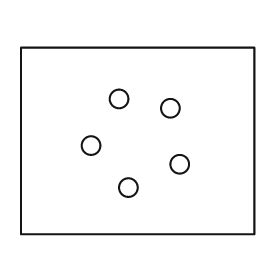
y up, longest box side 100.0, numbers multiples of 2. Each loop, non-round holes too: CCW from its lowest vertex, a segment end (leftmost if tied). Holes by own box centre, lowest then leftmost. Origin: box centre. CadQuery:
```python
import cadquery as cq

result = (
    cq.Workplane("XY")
    .moveTo(-50.0, -40.0)
    .lineTo(50.0, -40.0)
    .lineTo(50.0, 40.0)
    .lineTo(-50.0, 40.0)
    .close()
    .moveTo(-4.0, -20.0)
    .circle(4.0)
    .moveTo(18.0, -10.0)
    .circle(4.0)
    .moveTo(-20.0, -2.0)
    .circle(4.0)
    .moveTo(14.0, 14.0)
    .circle(4.0)
    .moveTo(-8.0, 18.0)
    .circle(4.0)
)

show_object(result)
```